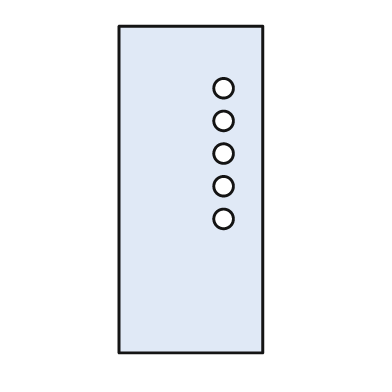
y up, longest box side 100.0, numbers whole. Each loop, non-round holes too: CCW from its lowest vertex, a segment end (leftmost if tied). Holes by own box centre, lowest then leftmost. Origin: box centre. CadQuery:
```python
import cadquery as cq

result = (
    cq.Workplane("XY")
    .moveTo(-22.0, -50.0)
    .lineTo(22.0, -50.0)
    .lineTo(22.0, 50.0)
    .lineTo(-22.0, 50.0)
    .close()
    .moveTo(10.0, -9.0)
    .circle(3.0)
    .moveTo(10.0, 1.0)
    .circle(3.0)
    .moveTo(10.0, 11.0)
    .circle(3.0)
    .moveTo(10.0, 21.0)
    .circle(3.0)
    .moveTo(10.0, 31.0)
    .circle(3.0)
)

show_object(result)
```